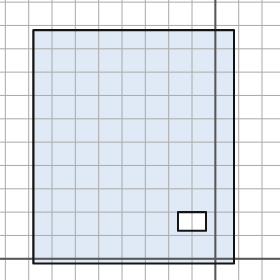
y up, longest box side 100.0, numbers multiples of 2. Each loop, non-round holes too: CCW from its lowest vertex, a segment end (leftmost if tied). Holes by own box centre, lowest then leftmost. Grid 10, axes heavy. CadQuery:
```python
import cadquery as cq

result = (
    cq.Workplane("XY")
    .moveTo(-78.0, -2.0)
    .lineTo(8.0, -2.0)
    .lineTo(8.0, 98.0)
    .lineTo(-78.0, 98.0)
    .close()
    .moveTo(-16.0, 12.0)
    .lineTo(-4.0, 12.0)
    .lineTo(-4.0, 20.0)
    .lineTo(-16.0, 20.0)
    .close()
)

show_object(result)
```